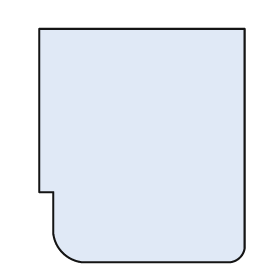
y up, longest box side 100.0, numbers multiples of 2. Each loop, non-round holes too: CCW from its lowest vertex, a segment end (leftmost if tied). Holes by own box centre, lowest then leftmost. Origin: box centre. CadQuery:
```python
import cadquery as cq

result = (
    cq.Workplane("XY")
    .moveTo(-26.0, -50.0)
    .lineTo(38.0, -50.0)
    .threePointArc((42.0, -48.0), (44.0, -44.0))
    .lineTo(44.0, 50.0)
    .lineTo(-44.0, 50.0)
    .lineTo(-44.0, -20.0)
    .lineTo(-38.0, -20.0)
    .lineTo(-38.0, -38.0)
    .threePointArc((-34.0, -46.0), (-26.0, -50.0))
    .close()
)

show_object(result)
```